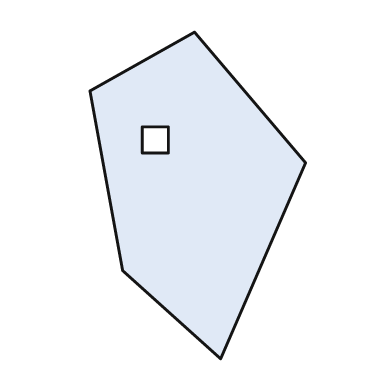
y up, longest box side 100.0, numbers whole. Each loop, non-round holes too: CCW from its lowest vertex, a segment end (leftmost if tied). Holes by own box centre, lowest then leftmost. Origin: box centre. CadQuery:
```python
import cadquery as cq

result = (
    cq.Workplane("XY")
    .moveTo(7.0, -50.0)
    .lineTo(33.0, 10.0)
    .lineTo(-1.0, 50.0)
    .lineTo(-33.0, 32.0)
    .lineTo(-23.0, -23.0)
    .close()
    .moveTo(-17.0, 13.0)
    .lineTo(-9.0, 13.0)
    .lineTo(-9.0, 21.0)
    .lineTo(-17.0, 21.0)
    .close()
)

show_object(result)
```